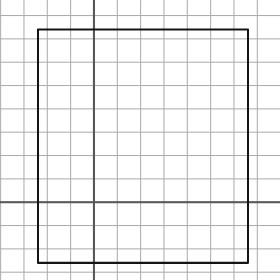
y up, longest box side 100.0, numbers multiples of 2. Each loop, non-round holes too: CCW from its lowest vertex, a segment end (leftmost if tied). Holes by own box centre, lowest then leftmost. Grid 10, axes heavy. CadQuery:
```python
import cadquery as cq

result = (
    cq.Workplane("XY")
    .moveTo(-24.0, -26.0)
    .lineTo(66.0, -26.0)
    .lineTo(66.0, 74.0)
    .lineTo(-24.0, 74.0)
    .close()
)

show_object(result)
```